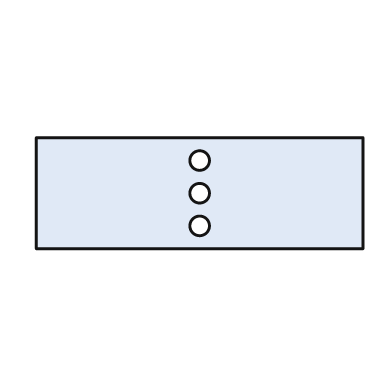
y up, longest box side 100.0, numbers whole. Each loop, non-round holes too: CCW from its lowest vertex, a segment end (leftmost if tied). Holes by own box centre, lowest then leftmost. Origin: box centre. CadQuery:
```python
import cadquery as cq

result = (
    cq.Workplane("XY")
    .moveTo(-50.0, -17.0)
    .lineTo(50.0, -17.0)
    .lineTo(50.0, 17.0)
    .lineTo(-50.0, 17.0)
    .close()
    .moveTo(0.0, -10.0)
    .circle(3.0)
    .moveTo(0.0, 0.0)
    .circle(3.0)
    .moveTo(0.0, 10.0)
    .circle(3.0)
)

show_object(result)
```